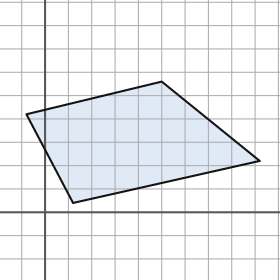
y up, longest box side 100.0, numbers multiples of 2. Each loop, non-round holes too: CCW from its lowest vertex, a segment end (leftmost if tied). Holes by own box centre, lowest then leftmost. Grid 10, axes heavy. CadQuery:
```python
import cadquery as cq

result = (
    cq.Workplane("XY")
    .moveTo(12.0, 4.0)
    .lineTo(92.0, 22.0)
    .lineTo(50.0, 56.0)
    .lineTo(-8.0, 42.0)
    .close()
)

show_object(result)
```